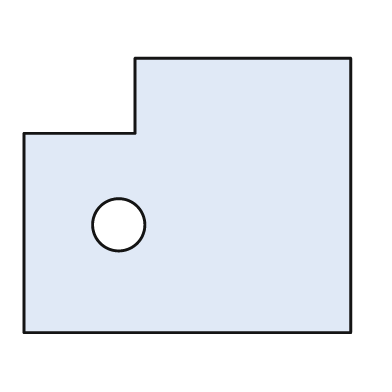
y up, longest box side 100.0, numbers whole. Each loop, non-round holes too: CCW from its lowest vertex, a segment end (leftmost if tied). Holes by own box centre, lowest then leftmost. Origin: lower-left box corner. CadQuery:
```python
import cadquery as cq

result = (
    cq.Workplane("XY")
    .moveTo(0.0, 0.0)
    .lineTo(100.0, 0.0)
    .lineTo(100.0, 84.0)
    .lineTo(34.0, 84.0)
    .lineTo(34.0, 61.0)
    .lineTo(0.0, 61.0)
    .close()
    .moveTo(29.0, 33.0)
    .circle(8.0)
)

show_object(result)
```